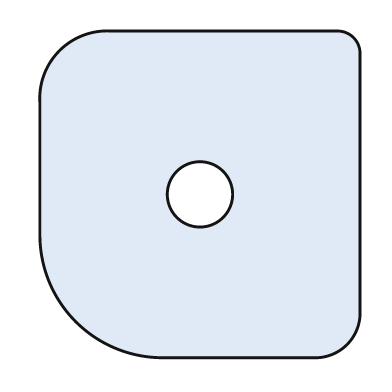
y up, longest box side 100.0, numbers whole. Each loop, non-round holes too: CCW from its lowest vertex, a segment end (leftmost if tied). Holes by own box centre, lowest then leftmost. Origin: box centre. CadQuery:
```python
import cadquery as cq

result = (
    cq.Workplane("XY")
    .moveTo(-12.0, -50.0)
    .lineTo(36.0, -50.0)
    .threePointArc((45.0, -46.0), (49.0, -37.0))
    .lineTo(49.0, 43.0)
    .threePointArc((47.0, 48.0), (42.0, 50.0))
    .lineTo(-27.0, 50.0)
    .threePointArc((-43.0, 44.0), (-49.0, 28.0))
    .lineTo(-49.0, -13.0)
    .threePointArc((-38.0, -39.0), (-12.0, -50.0))
    .close()
    .moveTo(0.0, 0.0)
    .circle(10.0)
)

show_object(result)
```